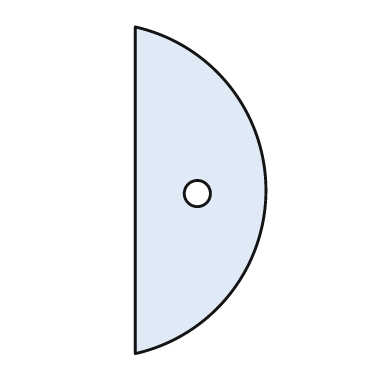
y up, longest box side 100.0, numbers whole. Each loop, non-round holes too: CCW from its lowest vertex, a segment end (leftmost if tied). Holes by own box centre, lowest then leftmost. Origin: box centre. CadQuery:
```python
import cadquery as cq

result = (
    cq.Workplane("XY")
    .moveTo(-20.0, -50.0)
    .threePointArc((20.0, 0.0), (-20.0, 50.0))
    .close()
    .moveTo(-1.0, -1.0)
    .circle(4.0)
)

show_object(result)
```